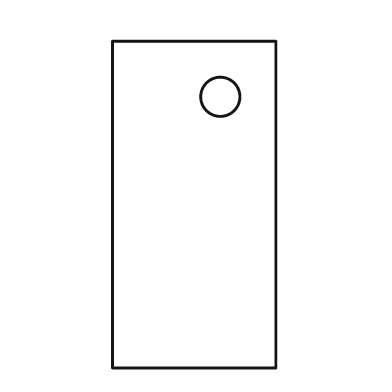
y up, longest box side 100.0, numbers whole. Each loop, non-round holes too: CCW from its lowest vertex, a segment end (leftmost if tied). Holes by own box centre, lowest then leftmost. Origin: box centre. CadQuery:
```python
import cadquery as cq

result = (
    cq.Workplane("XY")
    .moveTo(-25.0, -50.0)
    .lineTo(25.0, -50.0)
    .lineTo(25.0, 50.0)
    .lineTo(-25.0, 50.0)
    .close()
    .moveTo(8.0, 33.0)
    .circle(6.0)
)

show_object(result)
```